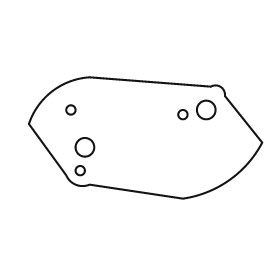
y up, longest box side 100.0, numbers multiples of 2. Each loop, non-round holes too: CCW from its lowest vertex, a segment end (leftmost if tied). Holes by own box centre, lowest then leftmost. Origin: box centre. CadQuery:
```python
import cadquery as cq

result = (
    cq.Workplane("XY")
    .moveTo(16.0, -26.0)
    .threePointArc((36.0, -18.0), (50.0, -2.0))
    .lineTo(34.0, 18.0)
    .threePointArc((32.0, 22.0), (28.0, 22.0))
    .lineTo(-24.0, 26.0)
    .threePointArc((-40.0, 20.0), (-50.0, 6.0))
    .lineTo(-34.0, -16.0)
    .threePointArc((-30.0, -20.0), (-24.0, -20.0))
    .close()
    .moveTo(-28.0, -14.0)
    .circle(2.0)
    .moveTo(-26.0, -4.0)
    .circle(4.0)
    .moveTo(16.0, 10.0)
    .circle(2.0)
    .moveTo(-32.0, 12.0)
    .circle(2.0)
    .moveTo(26.0, 12.0)
    .circle(4.0)
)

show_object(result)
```